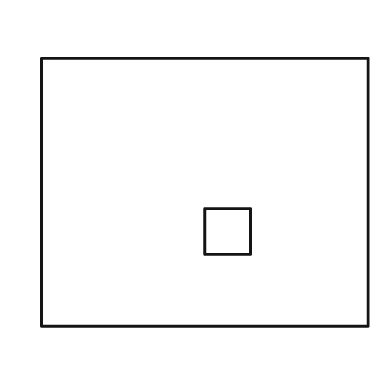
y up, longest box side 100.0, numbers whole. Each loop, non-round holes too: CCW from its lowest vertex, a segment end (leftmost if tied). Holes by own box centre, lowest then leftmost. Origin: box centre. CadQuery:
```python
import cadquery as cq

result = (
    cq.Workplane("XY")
    .moveTo(-50.0, -41.0)
    .lineTo(50.0, -41.0)
    .lineTo(50.0, 41.0)
    .lineTo(-50.0, 41.0)
    .close()
    .moveTo(0.0, -19.0)
    .lineTo(14.0, -19.0)
    .lineTo(14.0, -5.0)
    .lineTo(0.0, -5.0)
    .close()
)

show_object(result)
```